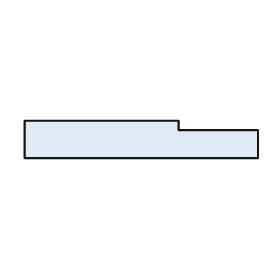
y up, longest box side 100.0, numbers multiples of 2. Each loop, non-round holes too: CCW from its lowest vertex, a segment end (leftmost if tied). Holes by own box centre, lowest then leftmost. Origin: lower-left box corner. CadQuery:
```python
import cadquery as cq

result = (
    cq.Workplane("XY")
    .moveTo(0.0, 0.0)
    .lineTo(100.0, 0.0)
    .lineTo(100.0, 12.0)
    .lineTo(66.0, 12.0)
    .lineTo(66.0, 16.0)
    .lineTo(0.0, 16.0)
    .close()
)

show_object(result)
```